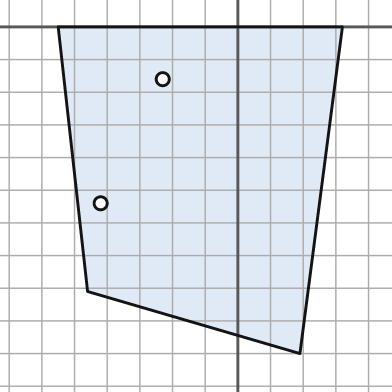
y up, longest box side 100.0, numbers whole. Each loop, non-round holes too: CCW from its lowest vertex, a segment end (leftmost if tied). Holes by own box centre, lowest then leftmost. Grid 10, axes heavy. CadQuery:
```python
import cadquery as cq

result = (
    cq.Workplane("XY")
    .moveTo(19.0, -100.0)
    .lineTo(32.0, 0.0)
    .lineTo(-55.0, 0.0)
    .lineTo(-46.0, -81.0)
    .close()
    .moveTo(-42.0, -54.0)
    .circle(2.0)
    .moveTo(-23.0, -16.0)
    .circle(2.0)
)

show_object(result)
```